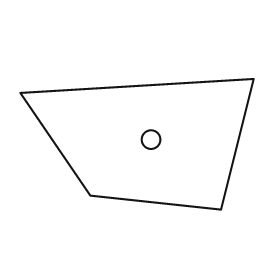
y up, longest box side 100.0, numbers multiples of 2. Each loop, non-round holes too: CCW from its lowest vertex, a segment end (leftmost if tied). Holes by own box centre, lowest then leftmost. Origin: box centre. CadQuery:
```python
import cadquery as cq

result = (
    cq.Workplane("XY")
    .moveTo(36.0, -28.0)
    .lineTo(50.0, 28.0)
    .lineTo(-50.0, 22.0)
    .lineTo(-20.0, -22.0)
    .close()
    .moveTo(6.0, 2.0)
    .circle(4.0)
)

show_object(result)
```